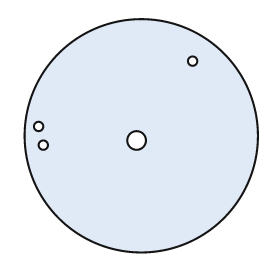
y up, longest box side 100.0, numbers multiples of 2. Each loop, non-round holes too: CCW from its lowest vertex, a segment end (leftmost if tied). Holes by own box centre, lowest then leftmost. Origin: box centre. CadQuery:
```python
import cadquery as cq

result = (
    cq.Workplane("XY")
    .moveTo(0.0, 0.0)
    .circle(50.0)
    .moveTo(-42.0, -4.0)
    .circle(2.0)
    .moveTo(-2.0, -2.0)
    .circle(4.0)
    .moveTo(-44.0, 4.0)
    .circle(2.0)
    .moveTo(22.0, 32.0)
    .circle(2.0)
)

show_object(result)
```